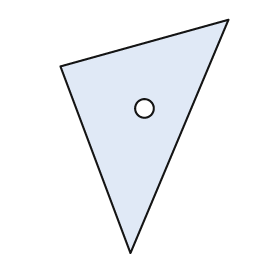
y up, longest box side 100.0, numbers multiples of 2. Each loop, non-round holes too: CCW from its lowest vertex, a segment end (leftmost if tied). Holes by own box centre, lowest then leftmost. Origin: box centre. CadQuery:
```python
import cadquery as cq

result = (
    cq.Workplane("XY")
    .moveTo(-6.0, -50.0)
    .lineTo(36.0, 50.0)
    .lineTo(-36.0, 30.0)
    .close()
    .moveTo(0.0, 12.0)
    .circle(4.0)
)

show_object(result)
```